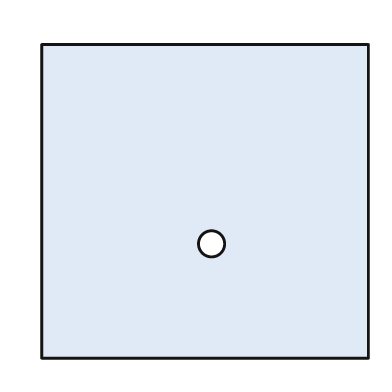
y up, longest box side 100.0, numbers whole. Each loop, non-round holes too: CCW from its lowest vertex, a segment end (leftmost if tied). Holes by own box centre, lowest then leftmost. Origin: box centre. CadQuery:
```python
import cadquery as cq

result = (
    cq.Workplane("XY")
    .moveTo(-50.0, -48.0)
    .lineTo(50.0, -48.0)
    .lineTo(50.0, 48.0)
    .lineTo(-50.0, 48.0)
    .close()
    .moveTo(2.0, -13.0)
    .circle(4.0)
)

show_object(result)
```